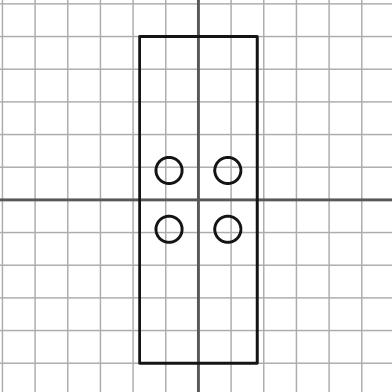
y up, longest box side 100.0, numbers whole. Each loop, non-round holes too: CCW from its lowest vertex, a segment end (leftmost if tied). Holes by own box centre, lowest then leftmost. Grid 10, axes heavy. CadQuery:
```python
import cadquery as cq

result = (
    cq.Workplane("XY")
    .moveTo(-18.0, -50.0)
    .lineTo(18.0, -50.0)
    .lineTo(18.0, 50.0)
    .lineTo(-18.0, 50.0)
    .close()
    .moveTo(-9.0, -9.0)
    .circle(4.0)
    .moveTo(9.0, -9.0)
    .circle(4.0)
    .moveTo(-9.0, 9.0)
    .circle(4.0)
    .moveTo(9.0, 9.0)
    .circle(4.0)
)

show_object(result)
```